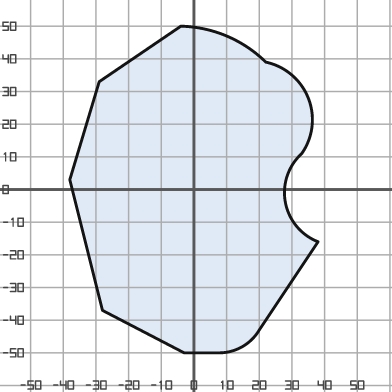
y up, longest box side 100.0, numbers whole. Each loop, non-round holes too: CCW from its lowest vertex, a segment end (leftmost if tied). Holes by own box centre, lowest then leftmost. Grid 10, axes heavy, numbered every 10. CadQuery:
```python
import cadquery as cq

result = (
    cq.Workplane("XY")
    .moveTo(-3.0, -50.0)
    .lineTo(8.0, -50.0)
    .threePointArc((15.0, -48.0), (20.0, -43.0))
    .lineTo(38.0, -16.0)
    .threePointArc((28.0, -4.0), (33.0, 11.0))
    .threePointArc((35.0, 28.0), (22.0, 39.0))
    .threePointArc((10.0, 47.0), (-4.0, 50.0))
    .lineTo(-29.0, 33.0)
    .lineTo(-38.0, 3.0)
    .lineTo(-28.0, -37.0)
    .close()
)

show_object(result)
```